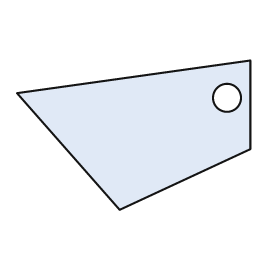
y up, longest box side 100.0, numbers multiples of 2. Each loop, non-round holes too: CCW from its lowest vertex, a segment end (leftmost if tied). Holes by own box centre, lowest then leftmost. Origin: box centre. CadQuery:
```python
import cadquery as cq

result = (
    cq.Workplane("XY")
    .moveTo(-6.0, -32.0)
    .lineTo(50.0, -6.0)
    .lineTo(50.0, 32.0)
    .lineTo(-50.0, 18.0)
    .close()
    .moveTo(40.0, 16.0)
    .circle(6.0)
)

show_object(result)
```